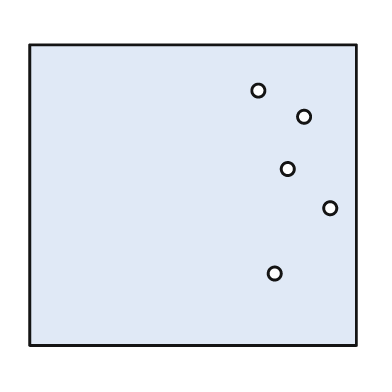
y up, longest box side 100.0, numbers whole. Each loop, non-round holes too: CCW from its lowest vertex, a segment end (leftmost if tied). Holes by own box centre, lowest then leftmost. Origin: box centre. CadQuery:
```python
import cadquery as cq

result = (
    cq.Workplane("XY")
    .moveTo(-50.0, -46.0)
    .lineTo(50.0, -46.0)
    .lineTo(50.0, 46.0)
    .lineTo(-50.0, 46.0)
    .close()
    .moveTo(25.0, -24.0)
    .circle(2.0)
    .moveTo(42.0, -4.0)
    .circle(2.0)
    .moveTo(29.0, 8.0)
    .circle(2.0)
    .moveTo(34.0, 24.0)
    .circle(2.0)
    .moveTo(20.0, 32.0)
    .circle(2.0)
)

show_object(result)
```